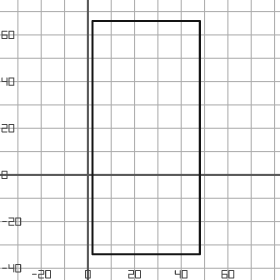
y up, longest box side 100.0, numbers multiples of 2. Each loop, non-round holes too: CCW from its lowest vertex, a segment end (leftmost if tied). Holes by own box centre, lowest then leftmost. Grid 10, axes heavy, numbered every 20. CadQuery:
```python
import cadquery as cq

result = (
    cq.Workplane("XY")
    .moveTo(2.0, -34.0)
    .lineTo(48.0, -34.0)
    .lineTo(48.0, 66.0)
    .lineTo(2.0, 66.0)
    .close()
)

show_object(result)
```